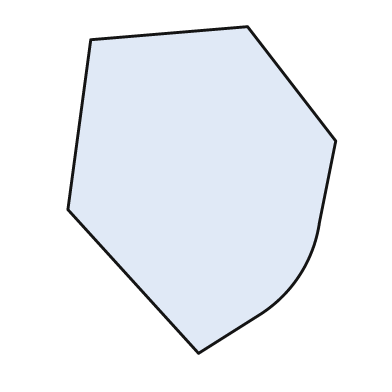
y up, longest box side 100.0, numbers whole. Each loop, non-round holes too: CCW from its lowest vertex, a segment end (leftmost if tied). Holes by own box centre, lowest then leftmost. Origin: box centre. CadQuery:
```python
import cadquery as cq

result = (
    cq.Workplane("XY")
    .moveTo(-1.0, -50.0)
    .lineTo(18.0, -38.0)
    .threePointArc((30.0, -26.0), (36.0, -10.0))
    .lineTo(41.0, 15.0)
    .lineTo(14.0, 50.0)
    .lineTo(-34.0, 46.0)
    .lineTo(-41.0, -6.0)
    .close()
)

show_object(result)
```